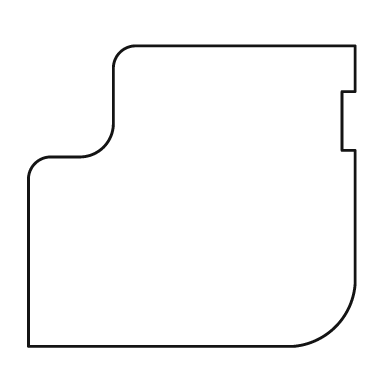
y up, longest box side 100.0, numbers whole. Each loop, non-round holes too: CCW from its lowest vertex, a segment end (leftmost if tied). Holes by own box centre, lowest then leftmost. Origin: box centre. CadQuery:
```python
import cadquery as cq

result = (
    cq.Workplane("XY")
    .moveTo(-50.0, -46.0)
    .lineTo(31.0, -46.0)
    .threePointArc((44.0, -40.0), (50.0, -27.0))
    .lineTo(50.0, 14.0)
    .lineTo(46.0, 14.0)
    .lineTo(46.0, 32.0)
    .lineTo(50.0, 32.0)
    .lineTo(50.0, 46.0)
    .lineTo(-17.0, 46.0)
    .threePointArc((-22.0, 44.0), (-24.0, 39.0))
    .lineTo(-24.0, 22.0)
    .threePointArc((-27.0, 15.0), (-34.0, 12.0))
    .lineTo(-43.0, 12.0)
    .threePointArc((-48.0, 10.0), (-50.0, 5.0))
    .close()
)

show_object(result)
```